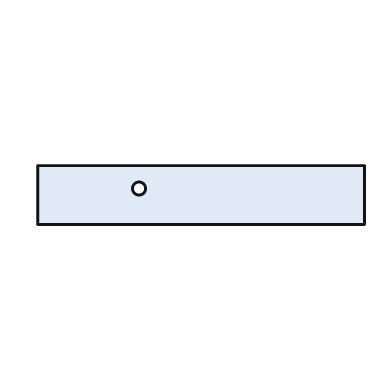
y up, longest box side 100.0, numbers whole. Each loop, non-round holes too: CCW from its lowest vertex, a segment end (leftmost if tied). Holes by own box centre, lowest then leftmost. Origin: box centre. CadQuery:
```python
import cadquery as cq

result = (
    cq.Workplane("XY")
    .moveTo(-50.0, -9.0)
    .lineTo(50.0, -9.0)
    .lineTo(50.0, 9.0)
    .lineTo(-50.0, 9.0)
    .close()
    .moveTo(-19.0, 2.0)
    .circle(2.0)
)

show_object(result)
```